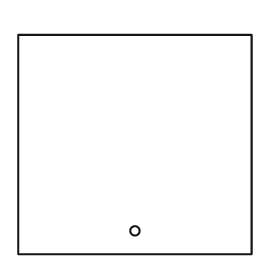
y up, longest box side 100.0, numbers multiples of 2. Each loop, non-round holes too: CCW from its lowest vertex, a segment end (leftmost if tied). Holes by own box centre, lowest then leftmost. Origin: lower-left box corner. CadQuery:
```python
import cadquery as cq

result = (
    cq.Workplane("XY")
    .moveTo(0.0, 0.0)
    .lineTo(100.0, 0.0)
    .lineTo(100.0, 94.0)
    .lineTo(0.0, 94.0)
    .close()
    .moveTo(50.0, 10.0)
    .circle(2.0)
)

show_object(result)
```